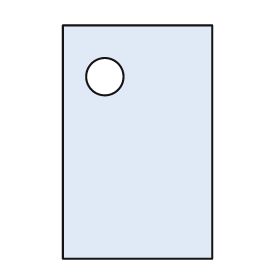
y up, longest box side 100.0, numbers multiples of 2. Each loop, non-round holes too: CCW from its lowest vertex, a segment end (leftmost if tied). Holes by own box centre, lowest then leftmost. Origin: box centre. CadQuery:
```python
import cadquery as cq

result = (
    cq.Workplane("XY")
    .moveTo(-32.0, -50.0)
    .lineTo(32.0, -50.0)
    .lineTo(32.0, 50.0)
    .lineTo(-32.0, 50.0)
    .close()
    .moveTo(-14.0, 28.0)
    .circle(8.0)
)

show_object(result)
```